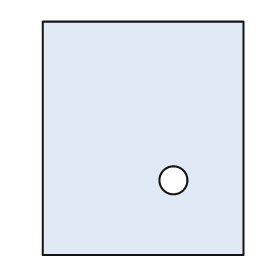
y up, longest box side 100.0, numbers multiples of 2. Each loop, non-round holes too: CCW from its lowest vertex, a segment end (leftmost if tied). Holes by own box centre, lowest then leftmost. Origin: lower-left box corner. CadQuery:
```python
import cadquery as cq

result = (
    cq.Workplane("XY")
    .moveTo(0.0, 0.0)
    .lineTo(86.0, 0.0)
    .lineTo(86.0, 100.0)
    .lineTo(0.0, 100.0)
    .close()
    .moveTo(56.0, 32.0)
    .circle(6.0)
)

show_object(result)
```